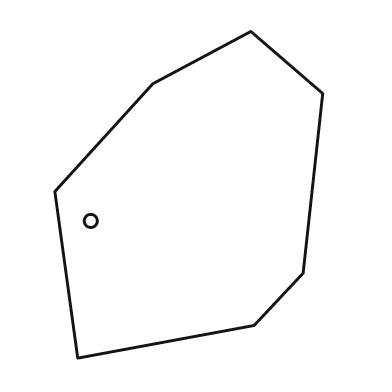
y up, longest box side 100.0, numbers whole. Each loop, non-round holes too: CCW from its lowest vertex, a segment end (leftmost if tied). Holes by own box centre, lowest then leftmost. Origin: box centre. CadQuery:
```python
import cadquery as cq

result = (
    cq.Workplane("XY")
    .moveTo(-34.0, -50.0)
    .lineTo(20.0, -40.0)
    .lineTo(35.0, -24.0)
    .lineTo(41.0, 31.0)
    .lineTo(19.0, 50.0)
    .lineTo(-11.0, 34.0)
    .lineTo(-41.0, 1.0)
    .close()
    .moveTo(-30.0, -8.0)
    .circle(2.0)
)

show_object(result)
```